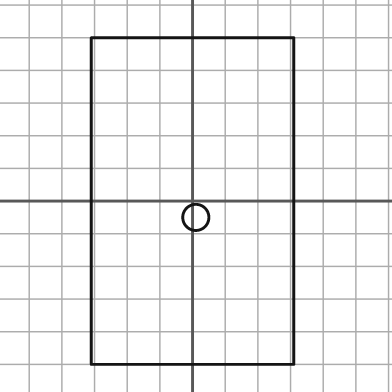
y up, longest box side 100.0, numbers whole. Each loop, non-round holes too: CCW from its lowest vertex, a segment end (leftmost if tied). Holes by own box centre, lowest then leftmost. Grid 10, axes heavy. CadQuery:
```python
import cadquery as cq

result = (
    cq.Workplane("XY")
    .moveTo(-31.0, -50.0)
    .lineTo(31.0, -50.0)
    .lineTo(31.0, 50.0)
    .lineTo(-31.0, 50.0)
    .close()
    .moveTo(1.0, -5.0)
    .circle(4.0)
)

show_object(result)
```